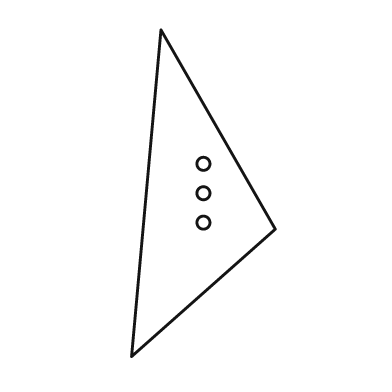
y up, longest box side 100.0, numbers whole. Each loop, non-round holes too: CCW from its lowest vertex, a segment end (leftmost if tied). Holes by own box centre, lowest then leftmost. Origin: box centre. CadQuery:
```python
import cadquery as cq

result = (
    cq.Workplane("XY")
    .moveTo(-22.0, -50.0)
    .lineTo(22.0, -11.0)
    .lineTo(-13.0, 50.0)
    .close()
    .moveTo(0.0, -9.0)
    .circle(2.0)
    .moveTo(0.0, 0.0)
    .circle(2.0)
    .moveTo(0.0, 9.0)
    .circle(2.0)
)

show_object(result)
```